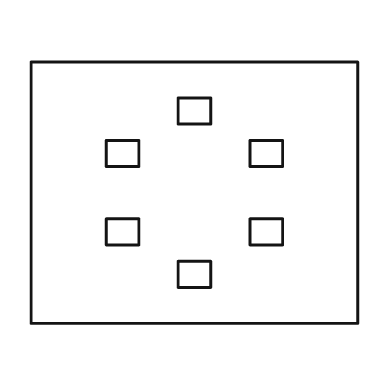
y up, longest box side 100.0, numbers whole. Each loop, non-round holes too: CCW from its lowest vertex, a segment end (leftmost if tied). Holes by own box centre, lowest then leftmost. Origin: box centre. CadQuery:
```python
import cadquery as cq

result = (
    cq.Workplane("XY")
    .moveTo(-50.0, -40.0)
    .lineTo(50.0, -40.0)
    .lineTo(50.0, 40.0)
    .lineTo(-50.0, 40.0)
    .close()
    .moveTo(-5.0, -29.0)
    .lineTo(5.0, -29.0)
    .lineTo(5.0, -21.0)
    .lineTo(-5.0, -21.0)
    .close()
    .moveTo(-27.0, -16.0)
    .lineTo(-17.0, -16.0)
    .lineTo(-17.0, -8.0)
    .lineTo(-27.0, -8.0)
    .close()
    .moveTo(17.0, -16.0)
    .lineTo(27.0, -16.0)
    .lineTo(27.0, -8.0)
    .lineTo(17.0, -8.0)
    .close()
    .moveTo(-27.0, 8.0)
    .lineTo(-17.0, 8.0)
    .lineTo(-17.0, 16.0)
    .lineTo(-27.0, 16.0)
    .close()
    .moveTo(17.0, 8.0)
    .lineTo(27.0, 8.0)
    .lineTo(27.0, 16.0)
    .lineTo(17.0, 16.0)
    .close()
    .moveTo(-5.0, 21.0)
    .lineTo(5.0, 21.0)
    .lineTo(5.0, 29.0)
    .lineTo(-5.0, 29.0)
    .close()
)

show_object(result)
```